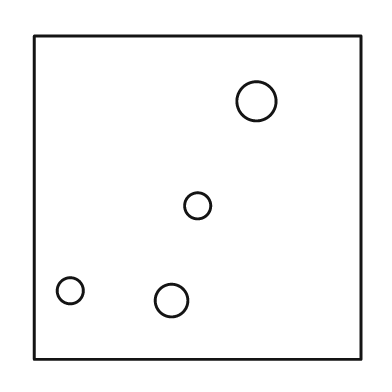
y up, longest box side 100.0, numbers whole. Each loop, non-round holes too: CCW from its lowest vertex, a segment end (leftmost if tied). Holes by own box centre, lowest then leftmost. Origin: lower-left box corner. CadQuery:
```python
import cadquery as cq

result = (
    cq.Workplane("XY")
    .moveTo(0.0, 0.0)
    .lineTo(100.0, 0.0)
    .lineTo(100.0, 99.0)
    .lineTo(0.0, 99.0)
    .close()
    .moveTo(42.0, 18.0)
    .circle(5.0)
    .moveTo(11.0, 21.0)
    .circle(4.0)
    .moveTo(50.0, 47.0)
    .circle(4.0)
    .moveTo(68.0, 79.0)
    .circle(6.0)
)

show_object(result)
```